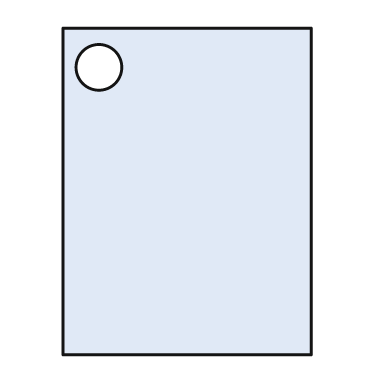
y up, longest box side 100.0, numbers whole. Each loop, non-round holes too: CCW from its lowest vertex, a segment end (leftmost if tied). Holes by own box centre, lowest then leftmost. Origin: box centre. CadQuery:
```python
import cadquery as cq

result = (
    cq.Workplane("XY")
    .moveTo(-38.0, -50.0)
    .lineTo(38.0, -50.0)
    .lineTo(38.0, 50.0)
    .lineTo(-38.0, 50.0)
    .close()
    .moveTo(-27.0, 38.0)
    .circle(7.0)
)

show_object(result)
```